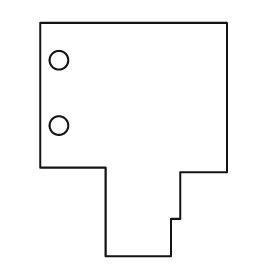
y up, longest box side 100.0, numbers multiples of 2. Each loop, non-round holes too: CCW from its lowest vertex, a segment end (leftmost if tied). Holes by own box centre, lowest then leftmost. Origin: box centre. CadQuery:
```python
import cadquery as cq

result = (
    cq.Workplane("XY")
    .moveTo(-12.0, -50.0)
    .lineTo(16.0, -50.0)
    .lineTo(16.0, -34.0)
    .lineTo(20.0, -34.0)
    .lineTo(20.0, -14.0)
    .lineTo(40.0, -14.0)
    .lineTo(40.0, 50.0)
    .lineTo(-40.0, 50.0)
    .lineTo(-40.0, -12.0)
    .lineTo(-12.0, -12.0)
    .close()
    .moveTo(-32.0, 6.0)
    .circle(4.0)
    .moveTo(-32.0, 34.0)
    .circle(4.0)
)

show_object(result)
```